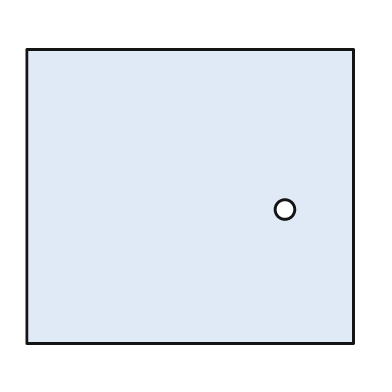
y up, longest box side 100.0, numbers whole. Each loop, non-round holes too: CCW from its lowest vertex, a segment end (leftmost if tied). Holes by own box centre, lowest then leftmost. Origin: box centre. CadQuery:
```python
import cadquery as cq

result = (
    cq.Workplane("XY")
    .moveTo(-50.0, -45.0)
    .lineTo(50.0, -45.0)
    .lineTo(50.0, 45.0)
    .lineTo(-50.0, 45.0)
    .close()
    .moveTo(29.0, -4.0)
    .circle(3.0)
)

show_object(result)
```